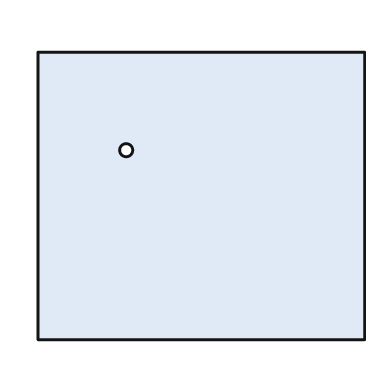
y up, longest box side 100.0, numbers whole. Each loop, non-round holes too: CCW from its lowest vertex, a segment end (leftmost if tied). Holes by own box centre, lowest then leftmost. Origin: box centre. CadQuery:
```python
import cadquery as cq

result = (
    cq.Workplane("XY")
    .moveTo(-50.0, -44.0)
    .lineTo(50.0, -44.0)
    .lineTo(50.0, 44.0)
    .lineTo(-50.0, 44.0)
    .close()
    .moveTo(-23.0, 14.0)
    .circle(2.0)
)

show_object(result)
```